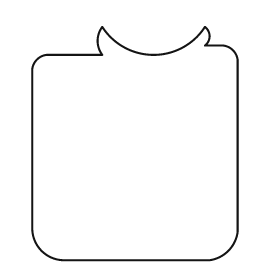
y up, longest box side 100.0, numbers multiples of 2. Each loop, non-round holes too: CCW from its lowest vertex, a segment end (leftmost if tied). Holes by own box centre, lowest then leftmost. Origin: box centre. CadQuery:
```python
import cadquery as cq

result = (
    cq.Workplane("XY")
    .moveTo(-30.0, -50.0)
    .lineTo(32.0, -50.0)
    .threePointArc((40.0, -46.0), (44.0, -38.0))
    .lineTo(44.0, 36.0)
    .threePointArc((42.0, 40.0), (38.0, 42.0))
    .lineTo(30.0, 42.0)
    .threePointArc((32.0, 46.0), (30.0, 50.0))
    .threePointArc((8.0, 38.0), (-14.0, 50.0))
    .threePointArc((-16.0, 44.0), (-14.0, 38.0))
    .lineTo(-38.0, 38.0)
    .threePointArc((-42.0, 36.0), (-44.0, 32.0))
    .lineTo(-44.0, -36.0)
    .threePointArc((-40.0, -46.0), (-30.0, -50.0))
    .close()
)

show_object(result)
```